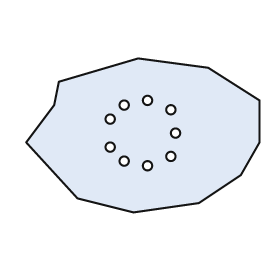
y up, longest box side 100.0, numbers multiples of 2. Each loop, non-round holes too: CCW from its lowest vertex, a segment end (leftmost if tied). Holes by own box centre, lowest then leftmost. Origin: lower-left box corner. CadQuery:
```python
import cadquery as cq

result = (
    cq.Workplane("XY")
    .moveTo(46.0, 0.0)
    .lineTo(74.0, 4.0)
    .lineTo(92.0, 16.0)
    .lineTo(100.0, 30.0)
    .lineTo(100.0, 48.0)
    .lineTo(78.0, 62.0)
    .lineTo(48.0, 66.0)
    .lineTo(14.0, 56.0)
    .lineTo(12.0, 46.0)
    .lineTo(0.0, 30.0)
    .lineTo(22.0, 6.0)
    .close()
    .moveTo(52.0, 20.0)
    .circle(2.0)
    .moveTo(42.0, 22.0)
    .circle(2.0)
    .moveTo(62.0, 24.0)
    .circle(2.0)
    .moveTo(36.0, 28.0)
    .circle(2.0)
    .moveTo(64.0, 34.0)
    .circle(2.0)
    .moveTo(36.0, 40.0)
    .circle(2.0)
    .moveTo(62.0, 44.0)
    .circle(2.0)
    .moveTo(42.0, 46.0)
    .circle(2.0)
    .moveTo(52.0, 48.0)
    .circle(2.0)
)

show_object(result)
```